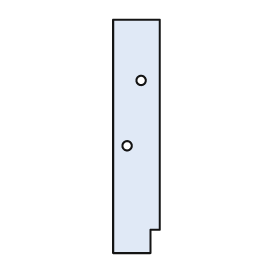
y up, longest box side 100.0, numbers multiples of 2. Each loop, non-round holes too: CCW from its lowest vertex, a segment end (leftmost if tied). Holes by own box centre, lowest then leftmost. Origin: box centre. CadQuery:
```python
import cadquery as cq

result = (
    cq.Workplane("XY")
    .moveTo(-10.0, -50.0)
    .lineTo(6.0, -50.0)
    .lineTo(6.0, -40.0)
    .lineTo(10.0, -40.0)
    .lineTo(10.0, 50.0)
    .lineTo(-10.0, 50.0)
    .close()
    .moveTo(-4.0, -4.0)
    .circle(2.0)
    .moveTo(2.0, 24.0)
    .circle(2.0)
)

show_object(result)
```